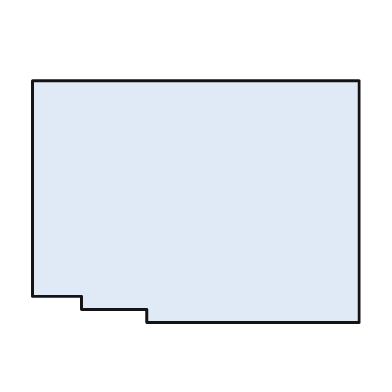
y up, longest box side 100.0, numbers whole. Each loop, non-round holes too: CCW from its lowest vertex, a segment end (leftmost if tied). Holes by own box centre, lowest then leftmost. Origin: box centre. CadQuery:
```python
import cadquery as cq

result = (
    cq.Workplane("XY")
    .moveTo(-15.0, -37.0)
    .lineTo(50.0, -37.0)
    .lineTo(50.0, 37.0)
    .lineTo(-50.0, 37.0)
    .lineTo(-50.0, -29.0)
    .lineTo(-35.0, -29.0)
    .lineTo(-35.0, -33.0)
    .lineTo(-15.0, -33.0)
    .close()
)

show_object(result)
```